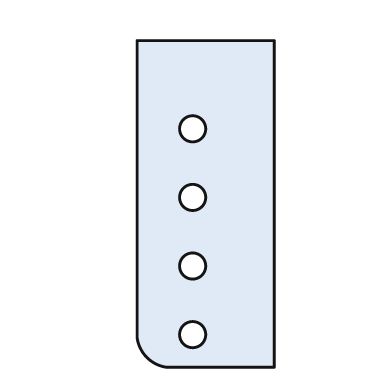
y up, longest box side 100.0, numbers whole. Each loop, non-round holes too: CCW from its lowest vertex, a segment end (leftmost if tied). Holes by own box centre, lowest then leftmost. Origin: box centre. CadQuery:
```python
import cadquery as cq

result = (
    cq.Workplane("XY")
    .moveTo(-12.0, -50.0)
    .lineTo(21.0, -50.0)
    .lineTo(21.0, 50.0)
    .lineTo(-21.0, 50.0)
    .lineTo(-21.0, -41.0)
    .threePointArc((-18.0, -47.0), (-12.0, -50.0))
    .close()
    .moveTo(-4.0, -40.0)
    .circle(4.0)
    .moveTo(-4.0, -19.0)
    .circle(4.0)
    .moveTo(-4.0, 2.0)
    .circle(4.0)
    .moveTo(-4.0, 23.0)
    .circle(4.0)
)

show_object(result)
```